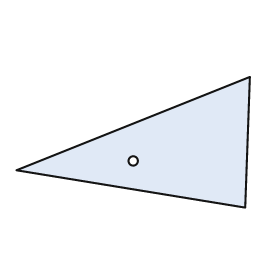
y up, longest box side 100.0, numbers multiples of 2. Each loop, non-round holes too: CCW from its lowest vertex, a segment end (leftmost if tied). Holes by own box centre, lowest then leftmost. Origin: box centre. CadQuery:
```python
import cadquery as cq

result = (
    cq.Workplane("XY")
    .moveTo(48.0, -28.0)
    .lineTo(50.0, 28.0)
    .lineTo(-50.0, -12.0)
    .close()
    .moveTo(0.0, -8.0)
    .circle(2.0)
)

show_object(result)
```